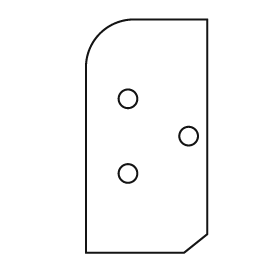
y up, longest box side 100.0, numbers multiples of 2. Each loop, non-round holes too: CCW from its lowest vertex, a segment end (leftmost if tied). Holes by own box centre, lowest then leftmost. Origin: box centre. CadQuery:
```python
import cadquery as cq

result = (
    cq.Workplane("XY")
    .moveTo(-26.0, -50.0)
    .lineTo(16.0, -50.0)
    .lineTo(26.0, -42.0)
    .lineTo(26.0, 50.0)
    .lineTo(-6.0, 50.0)
    .threePointArc((-20.0, 44.0), (-26.0, 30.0))
    .close()
    .moveTo(-8.0, -16.0)
    .circle(4.0)
    .moveTo(18.0, 0.0)
    .circle(4.0)
    .moveTo(-8.0, 16.0)
    .circle(4.0)
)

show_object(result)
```